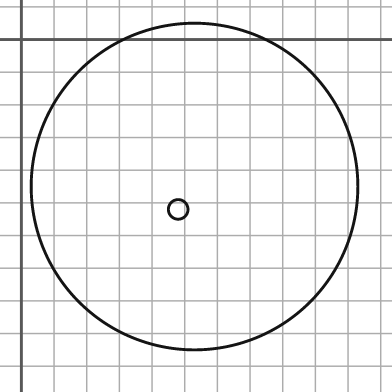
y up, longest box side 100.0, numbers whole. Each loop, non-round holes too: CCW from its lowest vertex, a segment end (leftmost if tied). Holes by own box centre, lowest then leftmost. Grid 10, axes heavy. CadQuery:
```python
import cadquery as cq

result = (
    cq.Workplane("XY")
    .moveTo(53.0, -45.0)
    .circle(50.0)
    .moveTo(48.0, -52.0)
    .circle(3.0)
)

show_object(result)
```